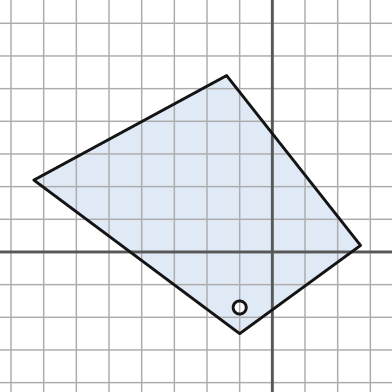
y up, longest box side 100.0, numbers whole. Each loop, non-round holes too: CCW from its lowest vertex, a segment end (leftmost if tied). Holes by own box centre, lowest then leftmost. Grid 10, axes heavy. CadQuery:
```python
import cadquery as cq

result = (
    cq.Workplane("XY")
    .moveTo(-10.0, -25.0)
    .lineTo(27.0, 2.0)
    .lineTo(-14.0, 54.0)
    .lineTo(-73.0, 22.0)
    .close()
    .moveTo(-10.0, -17.0)
    .circle(2.0)
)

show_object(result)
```